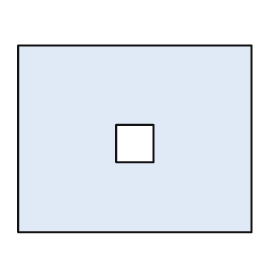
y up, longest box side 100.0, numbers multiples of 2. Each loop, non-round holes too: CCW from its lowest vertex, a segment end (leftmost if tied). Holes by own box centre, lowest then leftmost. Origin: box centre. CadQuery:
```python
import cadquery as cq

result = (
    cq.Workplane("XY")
    .moveTo(-50.0, -40.0)
    .lineTo(50.0, -40.0)
    .lineTo(50.0, 40.0)
    .lineTo(-50.0, 40.0)
    .close()
    .moveTo(-8.0, -10.0)
    .lineTo(8.0, -10.0)
    .lineTo(8.0, 6.0)
    .lineTo(-8.0, 6.0)
    .close()
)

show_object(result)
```